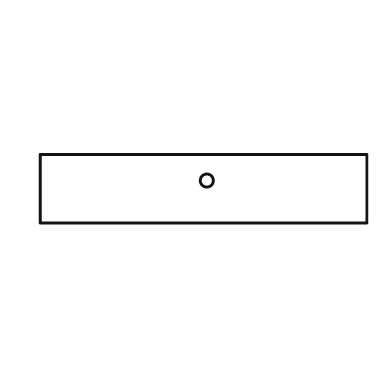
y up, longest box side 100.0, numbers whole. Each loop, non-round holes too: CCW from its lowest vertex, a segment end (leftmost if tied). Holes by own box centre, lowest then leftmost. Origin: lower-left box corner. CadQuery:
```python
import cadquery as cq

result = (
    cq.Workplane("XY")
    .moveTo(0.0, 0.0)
    .lineTo(100.0, 0.0)
    .lineTo(100.0, 21.0)
    .lineTo(0.0, 21.0)
    .close()
    .moveTo(51.0, 13.0)
    .circle(2.0)
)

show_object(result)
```